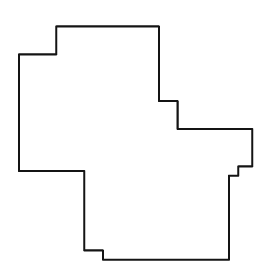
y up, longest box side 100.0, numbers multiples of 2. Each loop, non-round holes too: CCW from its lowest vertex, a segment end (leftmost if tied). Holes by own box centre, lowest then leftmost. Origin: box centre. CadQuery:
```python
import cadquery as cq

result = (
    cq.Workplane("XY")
    .moveTo(-14.0, -50.0)
    .lineTo(40.0, -50.0)
    .lineTo(40.0, -14.0)
    .lineTo(44.0, -14.0)
    .lineTo(44.0, -10.0)
    .lineTo(50.0, -10.0)
    .lineTo(50.0, 6.0)
    .lineTo(18.0, 6.0)
    .lineTo(18.0, 18.0)
    .lineTo(10.0, 18.0)
    .lineTo(10.0, 50.0)
    .lineTo(-34.0, 50.0)
    .lineTo(-34.0, 38.0)
    .lineTo(-50.0, 38.0)
    .lineTo(-50.0, -12.0)
    .lineTo(-22.0, -12.0)
    .lineTo(-22.0, -46.0)
    .lineTo(-14.0, -46.0)
    .close()
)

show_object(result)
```